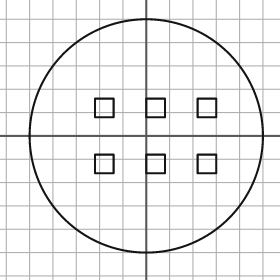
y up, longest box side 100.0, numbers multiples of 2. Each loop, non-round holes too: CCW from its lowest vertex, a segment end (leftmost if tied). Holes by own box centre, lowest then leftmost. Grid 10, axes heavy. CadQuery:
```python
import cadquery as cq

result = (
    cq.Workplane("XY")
    .moveTo(0.0, 0.0)
    .circle(50.0)
    .moveTo(-22.0, -16.0)
    .lineTo(-14.0, -16.0)
    .lineTo(-14.0, -8.0)
    .lineTo(-22.0, -8.0)
    .close()
    .moveTo(0.0, -16.0)
    .lineTo(8.0, -16.0)
    .lineTo(8.0, -8.0)
    .lineTo(0.0, -8.0)
    .close()
    .moveTo(22.0, -16.0)
    .lineTo(30.0, -16.0)
    .lineTo(30.0, -8.0)
    .lineTo(22.0, -8.0)
    .close()
    .moveTo(-22.0, 8.0)
    .lineTo(-14.0, 8.0)
    .lineTo(-14.0, 16.0)
    .lineTo(-22.0, 16.0)
    .close()
    .moveTo(0.0, 8.0)
    .lineTo(8.0, 8.0)
    .lineTo(8.0, 16.0)
    .lineTo(0.0, 16.0)
    .close()
    .moveTo(22.0, 8.0)
    .lineTo(30.0, 8.0)
    .lineTo(30.0, 16.0)
    .lineTo(22.0, 16.0)
    .close()
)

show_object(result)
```